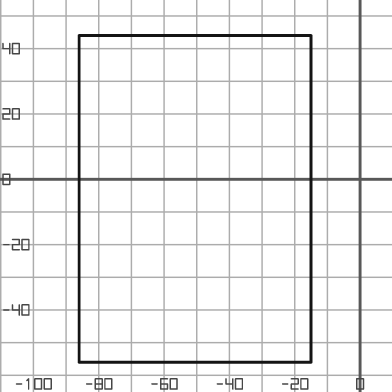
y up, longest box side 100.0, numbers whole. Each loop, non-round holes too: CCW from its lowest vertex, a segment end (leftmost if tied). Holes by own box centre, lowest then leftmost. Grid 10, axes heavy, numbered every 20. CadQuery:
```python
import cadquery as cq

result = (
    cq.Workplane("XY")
    .moveTo(-86.0, -56.0)
    .lineTo(-15.0, -56.0)
    .lineTo(-15.0, 44.0)
    .lineTo(-86.0, 44.0)
    .close()
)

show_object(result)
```